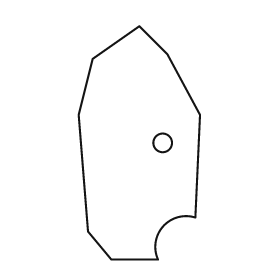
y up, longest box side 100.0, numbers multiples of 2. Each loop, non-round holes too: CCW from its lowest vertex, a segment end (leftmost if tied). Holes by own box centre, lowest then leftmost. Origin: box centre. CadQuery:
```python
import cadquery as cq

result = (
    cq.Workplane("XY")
    .moveTo(-12.0, -50.0)
    .lineTo(8.0, -50.0)
    .threePointArc((10.0, -36.0), (24.0, -32.0))
    .lineTo(26.0, 12.0)
    .lineTo(12.0, 38.0)
    .lineTo(0.0, 50.0)
    .lineTo(-20.0, 36.0)
    .lineTo(-26.0, 12.0)
    .lineTo(-22.0, -38.0)
    .close()
    .moveTo(10.0, 0.0)
    .circle(4.0)
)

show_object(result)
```